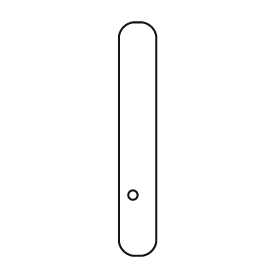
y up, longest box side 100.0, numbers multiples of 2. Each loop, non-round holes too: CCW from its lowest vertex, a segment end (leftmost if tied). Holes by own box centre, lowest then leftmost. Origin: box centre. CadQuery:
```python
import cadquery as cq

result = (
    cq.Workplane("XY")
    .moveTo(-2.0, -50.0)
    .lineTo(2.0, -50.0)
    .threePointArc((6.0, -48.0), (8.0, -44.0))
    .lineTo(8.0, 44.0)
    .threePointArc((6.0, 48.0), (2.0, 50.0))
    .lineTo(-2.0, 50.0)
    .threePointArc((-6.0, 48.0), (-8.0, 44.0))
    .lineTo(-8.0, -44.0)
    .threePointArc((-6.0, -48.0), (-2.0, -50.0))
    .close()
    .moveTo(-2.0, -24.0)
    .circle(2.0)
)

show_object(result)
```